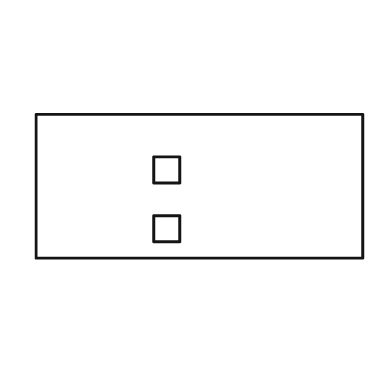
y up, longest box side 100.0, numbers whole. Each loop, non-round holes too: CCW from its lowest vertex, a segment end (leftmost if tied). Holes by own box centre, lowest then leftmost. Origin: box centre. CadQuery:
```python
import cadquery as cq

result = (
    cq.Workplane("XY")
    .moveTo(-50.0, -22.0)
    .lineTo(50.0, -22.0)
    .lineTo(50.0, 22.0)
    .lineTo(-50.0, 22.0)
    .close()
    .moveTo(-14.0, -17.0)
    .lineTo(-6.0, -17.0)
    .lineTo(-6.0, -9.0)
    .lineTo(-14.0, -9.0)
    .close()
    .moveTo(-14.0, 1.0)
    .lineTo(-6.0, 1.0)
    .lineTo(-6.0, 9.0)
    .lineTo(-14.0, 9.0)
    .close()
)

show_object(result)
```